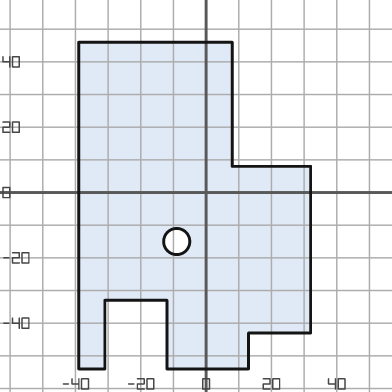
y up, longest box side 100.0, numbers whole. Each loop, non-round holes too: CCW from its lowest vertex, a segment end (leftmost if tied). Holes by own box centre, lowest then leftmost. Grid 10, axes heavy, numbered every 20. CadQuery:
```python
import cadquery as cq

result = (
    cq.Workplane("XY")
    .moveTo(-39.0, -54.0)
    .lineTo(-31.0, -54.0)
    .lineTo(-31.0, -33.0)
    .lineTo(-12.0, -33.0)
    .lineTo(-12.0, -54.0)
    .lineTo(13.0, -54.0)
    .lineTo(13.0, -43.0)
    .lineTo(32.0, -43.0)
    .lineTo(32.0, 8.0)
    .lineTo(8.0, 8.0)
    .lineTo(8.0, 46.0)
    .lineTo(-39.0, 46.0)
    .close()
    .moveTo(-9.0, -15.0)
    .circle(4.0)
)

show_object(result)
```